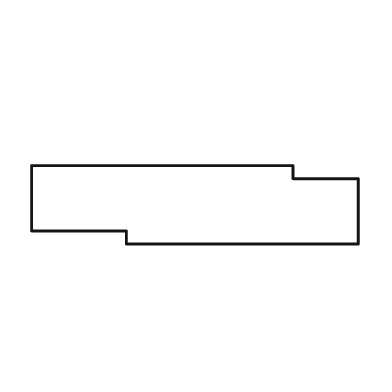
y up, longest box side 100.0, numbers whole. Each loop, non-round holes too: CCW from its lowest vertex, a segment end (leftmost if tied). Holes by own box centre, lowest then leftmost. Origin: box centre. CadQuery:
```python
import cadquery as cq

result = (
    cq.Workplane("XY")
    .moveTo(-21.0, -12.0)
    .lineTo(50.0, -12.0)
    .lineTo(50.0, 8.0)
    .lineTo(30.0, 8.0)
    .lineTo(30.0, 12.0)
    .lineTo(-50.0, 12.0)
    .lineTo(-50.0, -8.0)
    .lineTo(-21.0, -8.0)
    .close()
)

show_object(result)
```